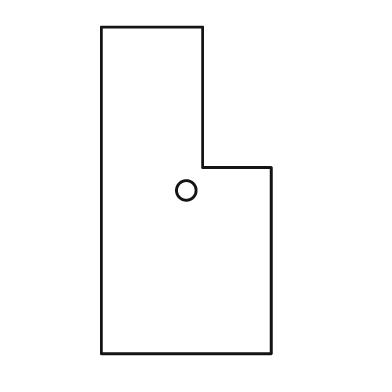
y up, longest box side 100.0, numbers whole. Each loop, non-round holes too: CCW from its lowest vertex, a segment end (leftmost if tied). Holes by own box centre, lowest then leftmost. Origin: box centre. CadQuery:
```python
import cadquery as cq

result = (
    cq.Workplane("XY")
    .moveTo(-26.0, -50.0)
    .lineTo(26.0, -50.0)
    .lineTo(26.0, 7.0)
    .lineTo(5.0, 7.0)
    .lineTo(5.0, 50.0)
    .lineTo(-26.0, 50.0)
    .close()
    .moveTo(0.0, 0.0)
    .circle(3.0)
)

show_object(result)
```